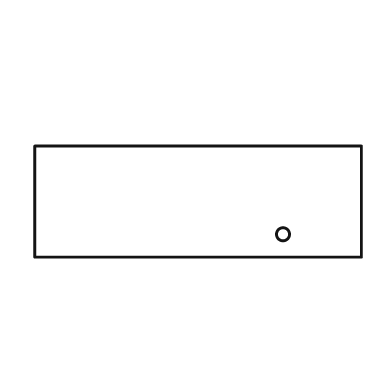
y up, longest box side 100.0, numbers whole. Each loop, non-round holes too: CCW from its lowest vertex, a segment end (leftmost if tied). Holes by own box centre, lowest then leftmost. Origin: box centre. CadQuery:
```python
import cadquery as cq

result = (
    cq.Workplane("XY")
    .moveTo(-50.0, -17.0)
    .lineTo(50.0, -17.0)
    .lineTo(50.0, 17.0)
    .lineTo(-50.0, 17.0)
    .close()
    .moveTo(26.0, -10.0)
    .circle(2.0)
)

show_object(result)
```